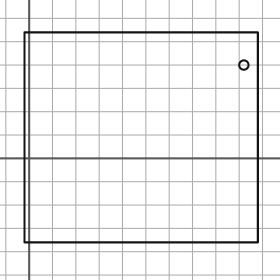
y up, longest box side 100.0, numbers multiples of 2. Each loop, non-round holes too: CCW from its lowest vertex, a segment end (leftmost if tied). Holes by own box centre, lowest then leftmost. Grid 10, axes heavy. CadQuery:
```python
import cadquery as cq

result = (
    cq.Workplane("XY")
    .moveTo(-2.0, -36.0)
    .lineTo(98.0, -36.0)
    .lineTo(98.0, 54.0)
    .lineTo(-2.0, 54.0)
    .close()
    .moveTo(92.0, 40.0)
    .circle(2.0)
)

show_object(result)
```